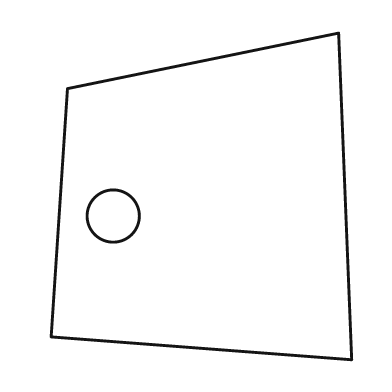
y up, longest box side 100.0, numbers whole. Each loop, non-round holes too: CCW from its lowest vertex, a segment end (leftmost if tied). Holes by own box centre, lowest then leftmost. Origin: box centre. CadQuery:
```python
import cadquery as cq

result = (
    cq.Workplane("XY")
    .moveTo(46.0, -50.0)
    .lineTo(42.0, 50.0)
    .lineTo(-41.0, 33.0)
    .lineTo(-46.0, -43.0)
    .close()
    .moveTo(-27.0, -6.0)
    .circle(8.0)
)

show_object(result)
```